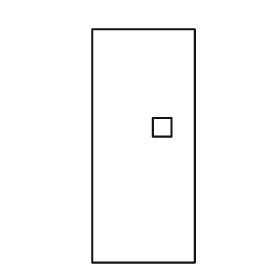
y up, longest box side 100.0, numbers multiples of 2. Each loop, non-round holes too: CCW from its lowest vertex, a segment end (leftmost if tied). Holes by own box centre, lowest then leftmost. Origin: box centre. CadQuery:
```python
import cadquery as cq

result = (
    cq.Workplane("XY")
    .moveTo(-22.0, -50.0)
    .lineTo(22.0, -50.0)
    .lineTo(22.0, 50.0)
    .lineTo(-22.0, 50.0)
    .close()
    .moveTo(4.0, 4.0)
    .lineTo(12.0, 4.0)
    .lineTo(12.0, 12.0)
    .lineTo(4.0, 12.0)
    .close()
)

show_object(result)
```